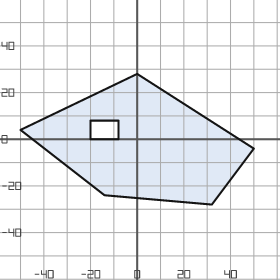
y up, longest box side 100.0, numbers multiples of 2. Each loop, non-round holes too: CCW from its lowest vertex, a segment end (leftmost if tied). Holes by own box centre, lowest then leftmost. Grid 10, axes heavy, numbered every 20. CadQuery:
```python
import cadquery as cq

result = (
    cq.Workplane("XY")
    .moveTo(32.0, -28.0)
    .lineTo(50.0, -4.0)
    .lineTo(0.0, 28.0)
    .lineTo(-50.0, 4.0)
    .lineTo(-14.0, -24.0)
    .close()
    .moveTo(-20.0, 0.0)
    .lineTo(-8.0, 0.0)
    .lineTo(-8.0, 8.0)
    .lineTo(-20.0, 8.0)
    .close()
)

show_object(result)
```